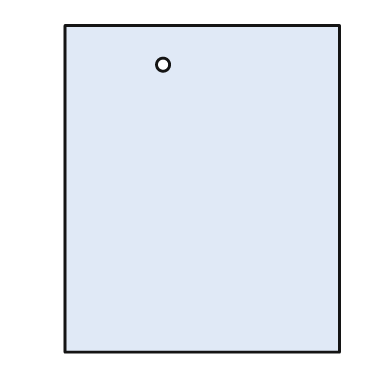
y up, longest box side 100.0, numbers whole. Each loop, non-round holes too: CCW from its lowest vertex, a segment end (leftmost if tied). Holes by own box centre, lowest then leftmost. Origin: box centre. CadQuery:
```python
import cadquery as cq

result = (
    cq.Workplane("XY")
    .moveTo(-42.0, -50.0)
    .lineTo(42.0, -50.0)
    .lineTo(42.0, 50.0)
    .lineTo(-42.0, 50.0)
    .close()
    .moveTo(-12.0, 38.0)
    .circle(2.0)
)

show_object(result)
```